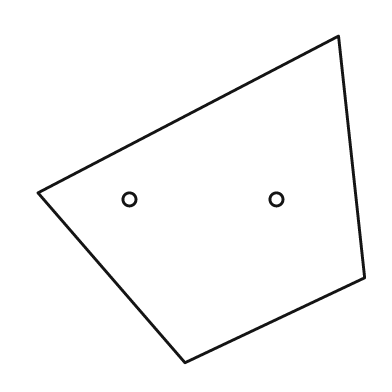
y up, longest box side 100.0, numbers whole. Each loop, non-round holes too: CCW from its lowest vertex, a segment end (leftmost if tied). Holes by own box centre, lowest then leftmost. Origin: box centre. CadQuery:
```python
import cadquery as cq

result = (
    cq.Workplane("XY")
    .moveTo(-5.0, -50.0)
    .lineTo(50.0, -24.0)
    .lineTo(42.0, 50.0)
    .lineTo(-50.0, 2.0)
    .close()
    .moveTo(-22.0, 0.0)
    .circle(2.0)
    .moveTo(23.0, 0.0)
    .circle(2.0)
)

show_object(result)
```